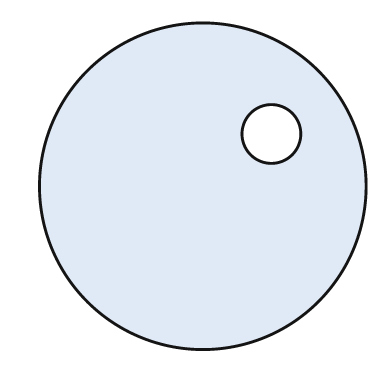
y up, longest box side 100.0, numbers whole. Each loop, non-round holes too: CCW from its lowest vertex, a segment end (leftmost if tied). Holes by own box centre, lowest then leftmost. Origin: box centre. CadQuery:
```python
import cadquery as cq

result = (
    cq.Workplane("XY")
    .moveTo(0.0, 0.0)
    .circle(50.0)
    .moveTo(21.0, 16.0)
    .circle(9.0)
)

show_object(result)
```